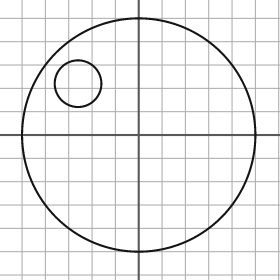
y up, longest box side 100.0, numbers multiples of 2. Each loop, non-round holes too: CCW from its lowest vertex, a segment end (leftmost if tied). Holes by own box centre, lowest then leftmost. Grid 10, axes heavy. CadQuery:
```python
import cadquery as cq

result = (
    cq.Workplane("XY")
    .moveTo(0.0, 0.0)
    .circle(50.0)
    .moveTo(-26.0, 22.0)
    .circle(10.0)
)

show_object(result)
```